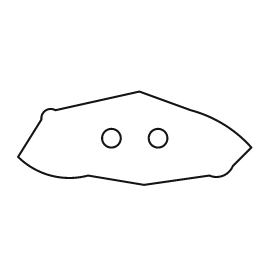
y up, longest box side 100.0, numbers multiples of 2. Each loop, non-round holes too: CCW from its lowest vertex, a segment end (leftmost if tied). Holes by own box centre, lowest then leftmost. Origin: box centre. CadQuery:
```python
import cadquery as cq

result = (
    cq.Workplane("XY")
    .moveTo(4.0, -20.0)
    .lineTo(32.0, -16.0)
    .threePointArc((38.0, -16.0), (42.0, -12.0))
    .lineTo(50.0, -4.0)
    .threePointArc((38.0, 6.0), (24.0, 12.0))
    .lineTo(2.0, 20.0)
    .lineTo(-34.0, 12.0)
    .threePointArc((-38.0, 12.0), (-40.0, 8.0))
    .lineTo(-50.0, -8.0)
    .threePointArc((-36.0, -16.0), (-20.0, -16.0))
    .close()
    .moveTo(-10.0, 0.0)
    .circle(4.0)
    .moveTo(10.0, 0.0)
    .circle(4.0)
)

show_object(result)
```